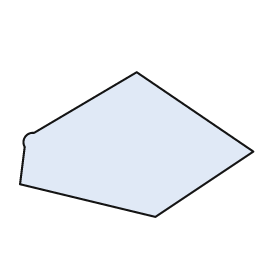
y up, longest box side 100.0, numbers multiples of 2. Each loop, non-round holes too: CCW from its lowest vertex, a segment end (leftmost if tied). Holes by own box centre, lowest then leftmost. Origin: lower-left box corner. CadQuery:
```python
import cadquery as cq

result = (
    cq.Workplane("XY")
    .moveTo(58.0, 0.0)
    .lineTo(100.0, 28.0)
    .lineTo(50.0, 62.0)
    .lineTo(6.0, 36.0)
    .threePointArc((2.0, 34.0), (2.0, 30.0))
    .lineTo(0.0, 14.0)
    .close()
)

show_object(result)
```